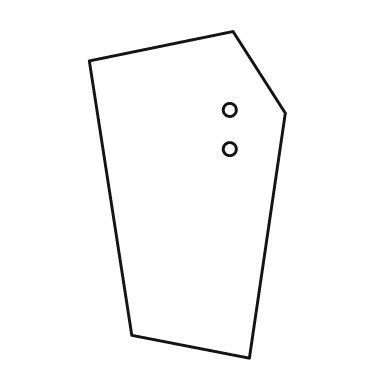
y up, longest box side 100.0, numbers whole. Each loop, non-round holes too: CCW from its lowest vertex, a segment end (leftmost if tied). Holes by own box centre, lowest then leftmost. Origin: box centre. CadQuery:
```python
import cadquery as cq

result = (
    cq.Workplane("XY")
    .moveTo(19.0, -50.0)
    .lineTo(30.0, 25.0)
    .lineTo(14.0, 50.0)
    .lineTo(-30.0, 41.0)
    .lineTo(-17.0, -43.0)
    .close()
    .moveTo(13.0, 14.0)
    .circle(2.0)
    .moveTo(13.0, 26.0)
    .circle(2.0)
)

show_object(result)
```